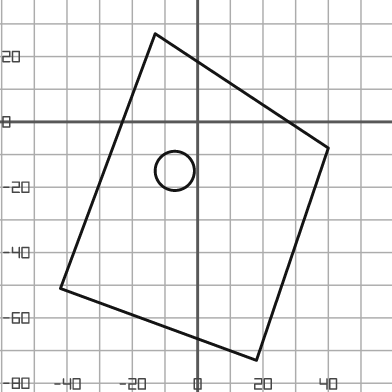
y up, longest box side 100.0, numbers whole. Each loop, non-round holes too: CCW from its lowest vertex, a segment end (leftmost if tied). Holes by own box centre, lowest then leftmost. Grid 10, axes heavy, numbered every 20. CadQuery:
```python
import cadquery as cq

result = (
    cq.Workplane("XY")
    .moveTo(18.0, -73.0)
    .lineTo(40.0, -8.0)
    .lineTo(-13.0, 27.0)
    .lineTo(-42.0, -51.0)
    .close()
    .moveTo(-7.0, -15.0)
    .circle(6.0)
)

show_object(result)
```